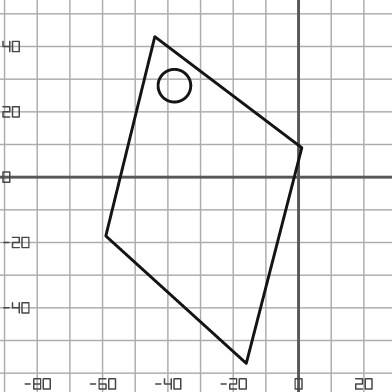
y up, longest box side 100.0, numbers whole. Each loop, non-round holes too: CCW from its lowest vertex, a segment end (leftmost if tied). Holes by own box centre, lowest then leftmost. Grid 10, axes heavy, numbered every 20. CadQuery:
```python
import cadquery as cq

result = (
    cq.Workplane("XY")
    .moveTo(-16.0, -57.0)
    .lineTo(1.0, 9.0)
    .lineTo(-44.0, 43.0)
    .lineTo(-59.0, -18.0)
    .close()
    .moveTo(-38.0, 28.0)
    .circle(5.0)
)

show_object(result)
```